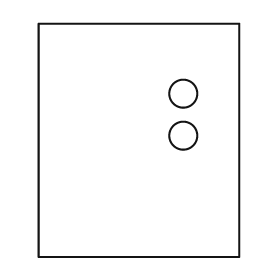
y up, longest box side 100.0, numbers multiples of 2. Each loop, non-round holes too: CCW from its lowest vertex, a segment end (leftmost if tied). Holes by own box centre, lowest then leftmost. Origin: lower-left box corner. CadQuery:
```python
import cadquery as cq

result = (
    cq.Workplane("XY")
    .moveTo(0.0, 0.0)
    .lineTo(86.0, 0.0)
    .lineTo(86.0, 100.0)
    .lineTo(0.0, 100.0)
    .close()
    .moveTo(62.0, 52.0)
    .circle(6.0)
    .moveTo(62.0, 70.0)
    .circle(6.0)
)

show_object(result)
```